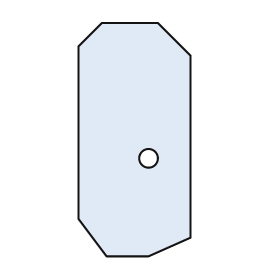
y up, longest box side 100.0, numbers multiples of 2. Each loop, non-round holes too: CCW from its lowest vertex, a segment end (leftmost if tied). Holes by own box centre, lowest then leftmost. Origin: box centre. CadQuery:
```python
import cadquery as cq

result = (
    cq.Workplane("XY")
    .moveTo(-12.0, -50.0)
    .lineTo(6.0, -50.0)
    .lineTo(24.0, -42.0)
    .lineTo(24.0, 36.0)
    .lineTo(10.0, 50.0)
    .lineTo(-14.0, 50.0)
    .lineTo(-24.0, 40.0)
    .lineTo(-24.0, -34.0)
    .close()
    .moveTo(6.0, -8.0)
    .circle(4.0)
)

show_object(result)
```